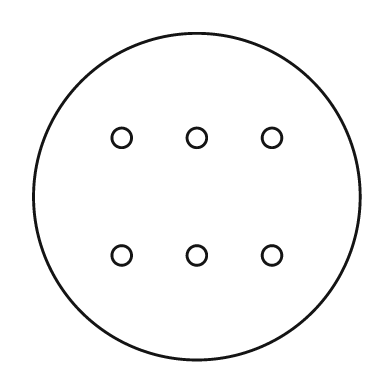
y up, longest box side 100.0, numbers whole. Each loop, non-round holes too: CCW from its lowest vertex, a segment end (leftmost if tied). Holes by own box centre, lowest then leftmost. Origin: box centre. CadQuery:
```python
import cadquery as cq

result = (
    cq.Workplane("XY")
    .moveTo(0.0, 0.0)
    .circle(50.0)
    .moveTo(-23.0, -18.0)
    .circle(3.0)
    .moveTo(0.0, -18.0)
    .circle(3.0)
    .moveTo(23.0, -18.0)
    .circle(3.0)
    .moveTo(-23.0, 18.0)
    .circle(3.0)
    .moveTo(0.0, 18.0)
    .circle(3.0)
    .moveTo(23.0, 18.0)
    .circle(3.0)
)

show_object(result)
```